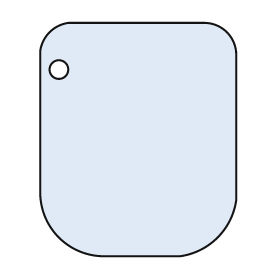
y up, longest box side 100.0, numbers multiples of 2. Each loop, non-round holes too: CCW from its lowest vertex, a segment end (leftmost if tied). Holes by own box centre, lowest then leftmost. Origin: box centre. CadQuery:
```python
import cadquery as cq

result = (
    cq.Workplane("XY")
    .moveTo(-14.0, -50.0)
    .lineTo(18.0, -50.0)
    .threePointArc((34.0, -42.0), (42.0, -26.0))
    .lineTo(42.0, 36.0)
    .threePointArc((38.0, 46.0), (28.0, 50.0))
    .lineTo(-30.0, 50.0)
    .threePointArc((-38.0, 46.0), (-42.0, 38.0))
    .lineTo(-42.0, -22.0)
    .threePointArc((-34.0, -42.0), (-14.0, -50.0))
    .close()
    .moveTo(-34.0, 30.0)
    .circle(4.0)
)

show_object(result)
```